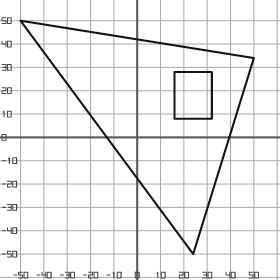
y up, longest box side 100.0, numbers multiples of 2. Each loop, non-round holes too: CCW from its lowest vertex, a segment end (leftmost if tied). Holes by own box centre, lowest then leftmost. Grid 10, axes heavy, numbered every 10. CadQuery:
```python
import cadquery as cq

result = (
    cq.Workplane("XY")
    .moveTo(24.0, -50.0)
    .lineTo(50.0, 34.0)
    .lineTo(-50.0, 50.0)
    .close()
    .moveTo(16.0, 8.0)
    .lineTo(32.0, 8.0)
    .lineTo(32.0, 28.0)
    .lineTo(16.0, 28.0)
    .close()
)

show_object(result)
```